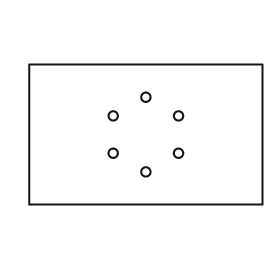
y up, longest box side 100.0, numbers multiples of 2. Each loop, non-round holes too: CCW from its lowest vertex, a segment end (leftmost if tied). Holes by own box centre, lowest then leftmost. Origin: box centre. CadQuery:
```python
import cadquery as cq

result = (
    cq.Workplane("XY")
    .moveTo(-50.0, -30.0)
    .lineTo(50.0, -30.0)
    .lineTo(50.0, 30.0)
    .lineTo(-50.0, 30.0)
    .close()
    .moveTo(0.0, -16.0)
    .circle(2.0)
    .moveTo(-14.0, -8.0)
    .circle(2.0)
    .moveTo(14.0, -8.0)
    .circle(2.0)
    .moveTo(-14.0, 8.0)
    .circle(2.0)
    .moveTo(14.0, 8.0)
    .circle(2.0)
    .moveTo(0.0, 16.0)
    .circle(2.0)
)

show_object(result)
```